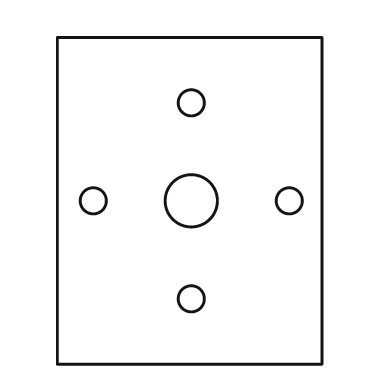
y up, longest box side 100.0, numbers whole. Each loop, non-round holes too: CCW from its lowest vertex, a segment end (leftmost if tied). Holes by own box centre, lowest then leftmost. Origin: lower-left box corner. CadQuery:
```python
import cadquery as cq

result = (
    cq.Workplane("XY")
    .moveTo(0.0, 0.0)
    .lineTo(81.0, 0.0)
    .lineTo(81.0, 100.0)
    .lineTo(0.0, 100.0)
    .close()
    .moveTo(41.0, 20.0)
    .circle(4.0)
    .moveTo(11.0, 50.0)
    .circle(4.0)
    .moveTo(41.0, 50.0)
    .circle(8.0)
    .moveTo(71.0, 50.0)
    .circle(4.0)
    .moveTo(41.0, 80.0)
    .circle(4.0)
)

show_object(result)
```